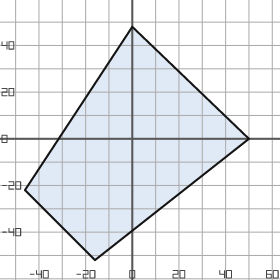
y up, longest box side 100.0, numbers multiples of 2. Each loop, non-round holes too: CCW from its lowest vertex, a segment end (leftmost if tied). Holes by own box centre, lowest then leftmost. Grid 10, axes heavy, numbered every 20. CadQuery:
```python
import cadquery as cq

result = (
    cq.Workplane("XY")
    .moveTo(-16.0, -52.0)
    .lineTo(50.0, 0.0)
    .lineTo(0.0, 48.0)
    .lineTo(-46.0, -22.0)
    .close()
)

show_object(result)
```